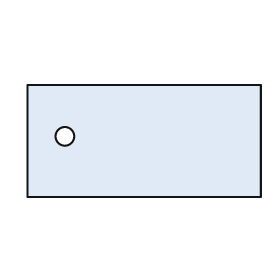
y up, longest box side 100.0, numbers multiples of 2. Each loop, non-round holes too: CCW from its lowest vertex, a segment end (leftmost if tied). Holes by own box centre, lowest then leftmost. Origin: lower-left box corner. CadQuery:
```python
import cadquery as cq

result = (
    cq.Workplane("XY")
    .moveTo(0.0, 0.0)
    .lineTo(100.0, 0.0)
    .lineTo(100.0, 48.0)
    .lineTo(0.0, 48.0)
    .close()
    .moveTo(16.0, 26.0)
    .circle(4.0)
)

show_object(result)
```